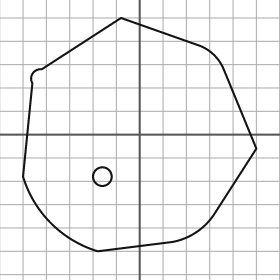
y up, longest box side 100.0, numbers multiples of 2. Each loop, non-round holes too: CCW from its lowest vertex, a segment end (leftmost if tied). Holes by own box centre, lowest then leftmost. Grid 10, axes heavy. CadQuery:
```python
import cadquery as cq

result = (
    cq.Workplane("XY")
    .moveTo(-18.0, -50.0)
    .lineTo(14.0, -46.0)
    .threePointArc((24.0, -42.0), (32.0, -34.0))
    .lineTo(50.0, -6.0)
    .lineTo(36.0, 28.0)
    .threePointArc((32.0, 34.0), (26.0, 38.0))
    .lineTo(-8.0, 50.0)
    .lineTo(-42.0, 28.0)
    .threePointArc((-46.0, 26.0), (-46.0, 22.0))
    .lineTo(-50.0, -18.0)
    .threePointArc((-38.0, -38.0), (-18.0, -50.0))
    .close()
    .moveTo(-16.0, -18.0)
    .circle(4.0)
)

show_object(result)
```